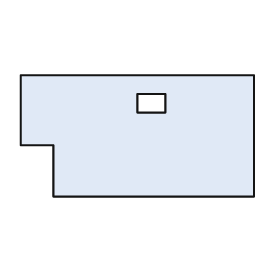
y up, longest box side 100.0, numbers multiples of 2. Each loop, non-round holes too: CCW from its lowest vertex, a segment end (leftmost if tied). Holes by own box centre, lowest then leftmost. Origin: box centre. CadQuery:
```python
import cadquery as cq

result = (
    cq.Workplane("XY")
    .moveTo(-36.0, -26.0)
    .lineTo(50.0, -26.0)
    .lineTo(50.0, 26.0)
    .lineTo(-50.0, 26.0)
    .lineTo(-50.0, -4.0)
    .lineTo(-36.0, -4.0)
    .close()
    .moveTo(0.0, 10.0)
    .lineTo(12.0, 10.0)
    .lineTo(12.0, 18.0)
    .lineTo(0.0, 18.0)
    .close()
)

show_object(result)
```